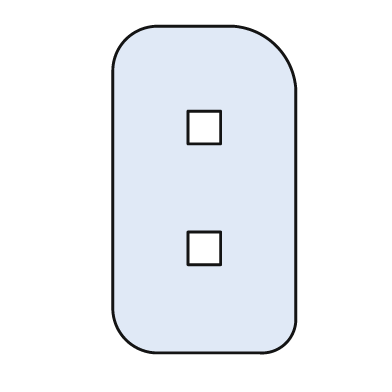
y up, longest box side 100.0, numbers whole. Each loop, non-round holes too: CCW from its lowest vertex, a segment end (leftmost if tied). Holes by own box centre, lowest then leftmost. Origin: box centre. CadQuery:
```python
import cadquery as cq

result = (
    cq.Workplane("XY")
    .moveTo(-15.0, -50.0)
    .lineTo(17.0, -50.0)
    .threePointArc((25.0, -47.0), (28.0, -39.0))
    .lineTo(28.0, 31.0)
    .threePointArc((22.0, 44.0), (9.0, 50.0))
    .lineTo(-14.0, 50.0)
    .threePointArc((-24.0, 46.0), (-28.0, 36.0))
    .lineTo(-28.0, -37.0)
    .threePointArc((-24.0, -46.0), (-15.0, -50.0))
    .close()
    .moveTo(-5.0, -23.0)
    .lineTo(5.0, -23.0)
    .lineTo(5.0, -13.0)
    .lineTo(-5.0, -13.0)
    .close()
    .moveTo(-5.0, 14.0)
    .lineTo(5.0, 14.0)
    .lineTo(5.0, 24.0)
    .lineTo(-5.0, 24.0)
    .close()
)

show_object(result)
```